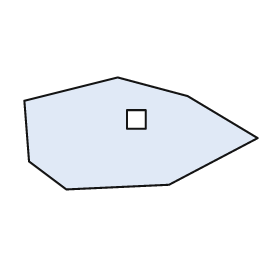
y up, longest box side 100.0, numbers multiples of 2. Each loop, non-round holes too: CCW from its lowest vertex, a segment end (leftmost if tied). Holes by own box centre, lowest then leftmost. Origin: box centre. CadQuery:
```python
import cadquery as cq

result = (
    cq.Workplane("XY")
    .moveTo(-32.0, -24.0)
    .lineTo(12.0, -22.0)
    .lineTo(50.0, -2.0)
    .lineTo(20.0, 16.0)
    .lineTo(-10.0, 24.0)
    .lineTo(-50.0, 14.0)
    .lineTo(-48.0, -12.0)
    .close()
    .moveTo(-6.0, 2.0)
    .lineTo(2.0, 2.0)
    .lineTo(2.0, 10.0)
    .lineTo(-6.0, 10.0)
    .close()
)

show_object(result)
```